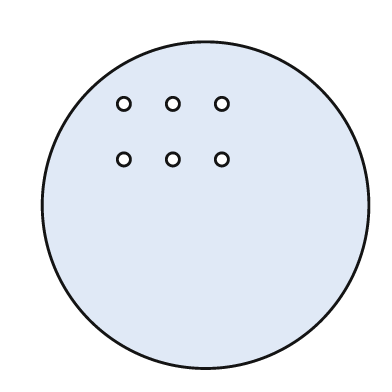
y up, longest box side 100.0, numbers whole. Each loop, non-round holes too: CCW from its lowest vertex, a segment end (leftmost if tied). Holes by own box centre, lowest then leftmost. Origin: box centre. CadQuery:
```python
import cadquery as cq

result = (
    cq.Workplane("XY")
    .moveTo(0.0, 0.0)
    .circle(50.0)
    .moveTo(-25.0, 14.0)
    .circle(2.0)
    .moveTo(-10.0, 14.0)
    .circle(2.0)
    .moveTo(5.0, 14.0)
    .circle(2.0)
    .moveTo(-25.0, 31.0)
    .circle(2.0)
    .moveTo(-10.0, 31.0)
    .circle(2.0)
    .moveTo(5.0, 31.0)
    .circle(2.0)
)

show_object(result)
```